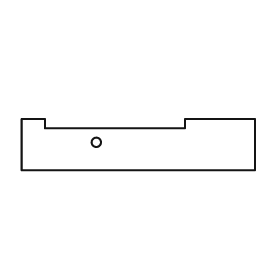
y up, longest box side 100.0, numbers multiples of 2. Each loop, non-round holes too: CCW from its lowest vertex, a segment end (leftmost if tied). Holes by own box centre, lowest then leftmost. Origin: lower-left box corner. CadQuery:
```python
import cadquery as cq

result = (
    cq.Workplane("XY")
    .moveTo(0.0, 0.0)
    .lineTo(100.0, 0.0)
    .lineTo(100.0, 22.0)
    .lineTo(70.0, 22.0)
    .lineTo(70.0, 18.0)
    .lineTo(10.0, 18.0)
    .lineTo(10.0, 22.0)
    .lineTo(0.0, 22.0)
    .close()
    .moveTo(32.0, 12.0)
    .circle(2.0)
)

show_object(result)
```